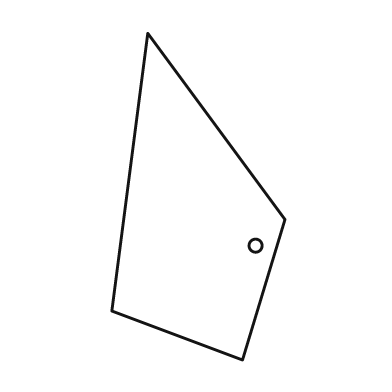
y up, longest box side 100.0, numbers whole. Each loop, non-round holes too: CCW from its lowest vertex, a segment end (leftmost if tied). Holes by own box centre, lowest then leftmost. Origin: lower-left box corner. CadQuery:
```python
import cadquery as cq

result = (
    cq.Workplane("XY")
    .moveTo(40.0, 0.0)
    .lineTo(53.0, 43.0)
    .lineTo(11.0, 100.0)
    .lineTo(0.0, 15.0)
    .close()
    .moveTo(44.0, 35.0)
    .circle(2.0)
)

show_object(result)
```